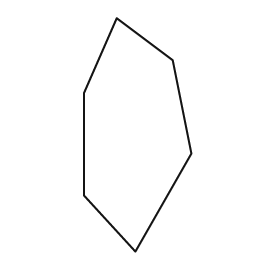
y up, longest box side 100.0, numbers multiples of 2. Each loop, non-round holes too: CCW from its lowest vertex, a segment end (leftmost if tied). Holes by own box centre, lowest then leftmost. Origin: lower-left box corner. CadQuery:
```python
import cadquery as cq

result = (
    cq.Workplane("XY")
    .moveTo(22.0, 0.0)
    .lineTo(46.0, 42.0)
    .lineTo(38.0, 82.0)
    .lineTo(14.0, 100.0)
    .lineTo(0.0, 68.0)
    .lineTo(0.0, 24.0)
    .close()
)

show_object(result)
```